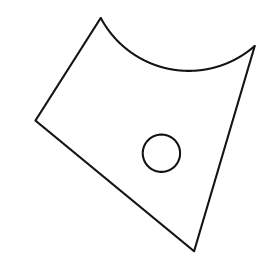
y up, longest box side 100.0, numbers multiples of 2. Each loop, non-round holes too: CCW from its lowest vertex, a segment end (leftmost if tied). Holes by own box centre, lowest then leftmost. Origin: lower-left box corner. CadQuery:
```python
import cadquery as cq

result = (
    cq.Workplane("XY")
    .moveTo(68.0, 0.0)
    .lineTo(94.0, 88.0)
    .threePointArc((58.0, 78.0), (28.0, 100.0))
    .lineTo(0.0, 56.0)
    .close()
    .moveTo(54.0, 42.0)
    .circle(8.0)
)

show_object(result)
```